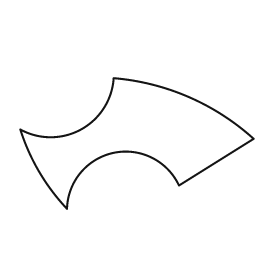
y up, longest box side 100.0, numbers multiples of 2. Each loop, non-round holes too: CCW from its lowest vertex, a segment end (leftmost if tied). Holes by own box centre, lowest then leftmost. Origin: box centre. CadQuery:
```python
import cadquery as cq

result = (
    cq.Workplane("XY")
    .moveTo(-30.0, -28.0)
    .threePointArc((-10.0, -4.0), (18.0, -18.0))
    .lineTo(50.0, 2.0)
    .threePointArc((22.0, 20.0), (-10.0, 28.0))
    .threePointArc((-24.0, 6.0), (-50.0, 6.0))
    .threePointArc((-42.0, -12.0), (-30.0, -28.0))
    .close()
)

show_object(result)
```